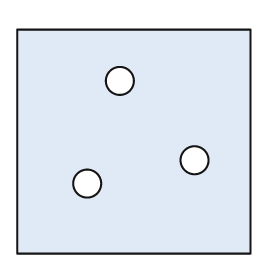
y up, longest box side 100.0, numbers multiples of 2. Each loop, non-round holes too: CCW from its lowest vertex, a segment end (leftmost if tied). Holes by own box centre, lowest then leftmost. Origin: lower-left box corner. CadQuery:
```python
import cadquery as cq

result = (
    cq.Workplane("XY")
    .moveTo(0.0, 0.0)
    .lineTo(100.0, 0.0)
    .lineTo(100.0, 96.0)
    .lineTo(0.0, 96.0)
    .close()
    .moveTo(30.0, 30.0)
    .circle(6.0)
    .moveTo(76.0, 40.0)
    .circle(6.0)
    .moveTo(44.0, 74.0)
    .circle(6.0)
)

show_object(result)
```